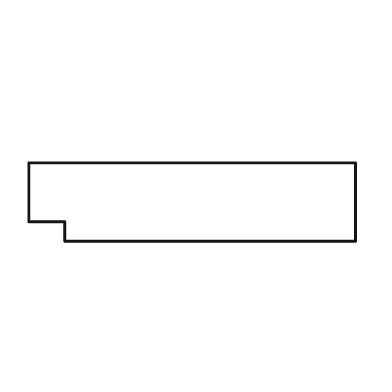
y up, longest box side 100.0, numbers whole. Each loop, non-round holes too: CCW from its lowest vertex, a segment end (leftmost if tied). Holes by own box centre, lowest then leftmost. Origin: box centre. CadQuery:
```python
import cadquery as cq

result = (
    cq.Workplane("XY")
    .moveTo(-39.0, -12.0)
    .lineTo(50.0, -12.0)
    .lineTo(50.0, 12.0)
    .lineTo(-50.0, 12.0)
    .lineTo(-50.0, -6.0)
    .lineTo(-39.0, -6.0)
    .close()
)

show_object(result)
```